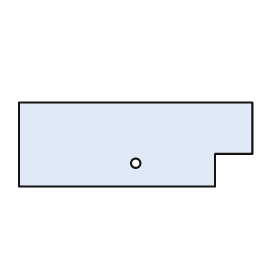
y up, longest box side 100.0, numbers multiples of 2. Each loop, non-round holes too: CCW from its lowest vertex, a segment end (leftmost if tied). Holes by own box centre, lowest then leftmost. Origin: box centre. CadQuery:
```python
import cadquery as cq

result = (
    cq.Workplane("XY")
    .moveTo(-50.0, -18.0)
    .lineTo(34.0, -18.0)
    .lineTo(34.0, -4.0)
    .lineTo(50.0, -4.0)
    .lineTo(50.0, 18.0)
    .lineTo(-50.0, 18.0)
    .close()
    .moveTo(0.0, -8.0)
    .circle(2.0)
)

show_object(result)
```